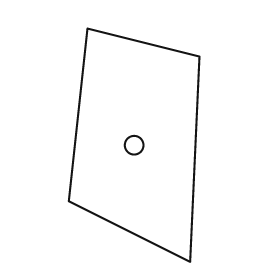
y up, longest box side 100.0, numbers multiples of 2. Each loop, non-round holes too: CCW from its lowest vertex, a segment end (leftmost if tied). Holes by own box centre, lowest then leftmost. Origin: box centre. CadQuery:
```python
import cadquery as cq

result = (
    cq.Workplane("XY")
    .moveTo(24.0, -50.0)
    .lineTo(28.0, 38.0)
    .lineTo(-20.0, 50.0)
    .lineTo(-28.0, -24.0)
    .close()
    .moveTo(0.0, 0.0)
    .circle(4.0)
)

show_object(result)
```